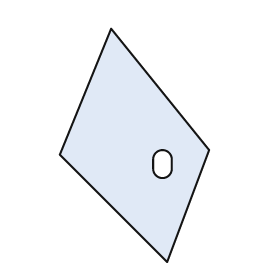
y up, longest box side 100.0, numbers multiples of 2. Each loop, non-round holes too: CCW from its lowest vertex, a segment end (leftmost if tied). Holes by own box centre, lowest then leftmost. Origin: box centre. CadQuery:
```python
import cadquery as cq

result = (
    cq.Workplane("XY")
    .moveTo(14.0, -50.0)
    .lineTo(32.0, -2.0)
    .lineTo(-10.0, 50.0)
    .lineTo(-32.0, -4.0)
    .close()
    .moveTo(8.0, -10.0)
    .threePointArc((12.0, -14.0), (16.0, -10.0))
    .lineTo(16.0, -6.0)
    .threePointArc((12.0, -2.0), (8.0, -6.0))
    .close()
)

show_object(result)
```